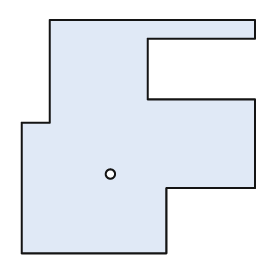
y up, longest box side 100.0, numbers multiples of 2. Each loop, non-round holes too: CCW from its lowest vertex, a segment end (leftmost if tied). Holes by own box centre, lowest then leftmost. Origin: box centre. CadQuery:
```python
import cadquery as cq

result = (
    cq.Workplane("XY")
    .moveTo(-50.0, -50.0)
    .lineTo(12.0, -50.0)
    .lineTo(12.0, -22.0)
    .lineTo(50.0, -22.0)
    .lineTo(50.0, 16.0)
    .lineTo(4.0, 16.0)
    .lineTo(4.0, 42.0)
    .lineTo(50.0, 42.0)
    .lineTo(50.0, 50.0)
    .lineTo(-38.0, 50.0)
    .lineTo(-38.0, 6.0)
    .lineTo(-50.0, 6.0)
    .close()
    .moveTo(-12.0, -16.0)
    .circle(2.0)
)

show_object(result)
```